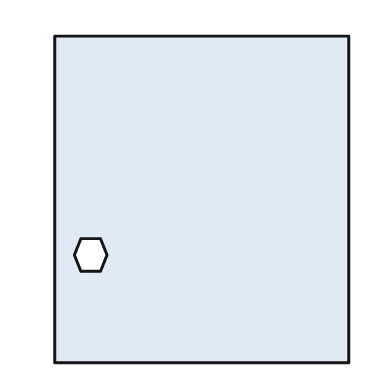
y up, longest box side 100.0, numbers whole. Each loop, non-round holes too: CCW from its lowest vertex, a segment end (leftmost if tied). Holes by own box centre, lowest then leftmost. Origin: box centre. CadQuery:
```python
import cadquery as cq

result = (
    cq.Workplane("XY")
    .moveTo(-45.0, -50.0)
    .lineTo(45.0, -50.0)
    .lineTo(45.0, 50.0)
    .lineTo(-45.0, 50.0)
    .close()
    .moveTo(-37.0, -22.0)
    .lineTo(-31.0, -22.0)
    .lineTo(-29.0, -17.0)
    .lineTo(-31.0, -12.0)
    .lineTo(-37.0, -12.0)
    .lineTo(-39.0, -17.0)
    .close()
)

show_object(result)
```